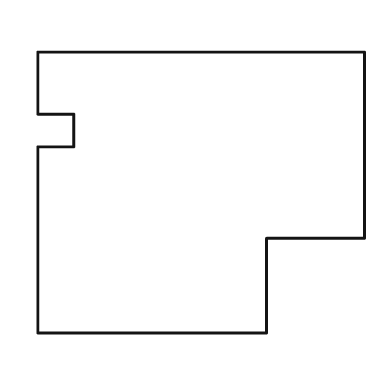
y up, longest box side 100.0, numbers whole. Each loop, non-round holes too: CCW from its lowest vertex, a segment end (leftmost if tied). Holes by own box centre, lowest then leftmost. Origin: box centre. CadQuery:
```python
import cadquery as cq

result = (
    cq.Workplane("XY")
    .moveTo(-50.0, -43.0)
    .lineTo(20.0, -43.0)
    .lineTo(20.0, -14.0)
    .lineTo(50.0, -14.0)
    .lineTo(50.0, 43.0)
    .lineTo(-50.0, 43.0)
    .lineTo(-50.0, 24.0)
    .lineTo(-39.0, 24.0)
    .lineTo(-39.0, 14.0)
    .lineTo(-50.0, 14.0)
    .close()
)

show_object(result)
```